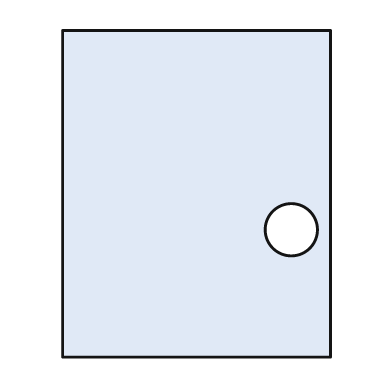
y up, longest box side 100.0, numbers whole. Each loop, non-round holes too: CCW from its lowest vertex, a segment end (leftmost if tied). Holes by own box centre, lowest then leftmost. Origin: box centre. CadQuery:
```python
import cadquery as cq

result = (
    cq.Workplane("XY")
    .moveTo(-41.0, -50.0)
    .lineTo(41.0, -50.0)
    .lineTo(41.0, 50.0)
    .lineTo(-41.0, 50.0)
    .close()
    .moveTo(29.0, -11.0)
    .circle(8.0)
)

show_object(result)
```